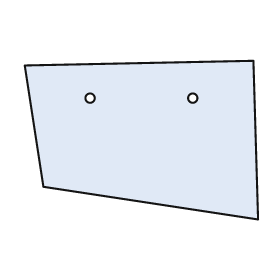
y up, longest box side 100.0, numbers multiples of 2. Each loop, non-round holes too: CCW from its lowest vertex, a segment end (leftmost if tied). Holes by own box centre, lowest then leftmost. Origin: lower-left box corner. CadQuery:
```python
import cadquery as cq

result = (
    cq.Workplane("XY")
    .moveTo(100.0, 0.0)
    .lineTo(98.0, 68.0)
    .lineTo(0.0, 66.0)
    .lineTo(8.0, 14.0)
    .close()
    .moveTo(28.0, 52.0)
    .circle(2.0)
    .moveTo(72.0, 52.0)
    .circle(2.0)
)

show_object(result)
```